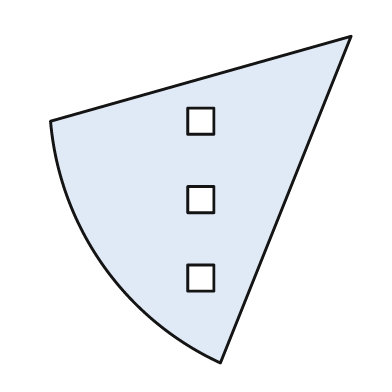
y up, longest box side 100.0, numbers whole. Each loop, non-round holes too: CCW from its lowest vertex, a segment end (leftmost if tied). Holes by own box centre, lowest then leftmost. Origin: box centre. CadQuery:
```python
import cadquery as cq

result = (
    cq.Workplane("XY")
    .moveTo(6.0, -50.0)
    .lineTo(46.0, 50.0)
    .lineTo(-46.0, 24.0)
    .threePointArc((-30.0, -20.0), (6.0, -50.0))
    .close()
    .moveTo(-4.0, -28.0)
    .lineTo(4.0, -28.0)
    .lineTo(4.0, -20.0)
    .lineTo(-4.0, -20.0)
    .close()
    .moveTo(-4.0, -4.0)
    .lineTo(4.0, -4.0)
    .lineTo(4.0, 4.0)
    .lineTo(-4.0, 4.0)
    .close()
    .moveTo(-4.0, 20.0)
    .lineTo(4.0, 20.0)
    .lineTo(4.0, 28.0)
    .lineTo(-4.0, 28.0)
    .close()
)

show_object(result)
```